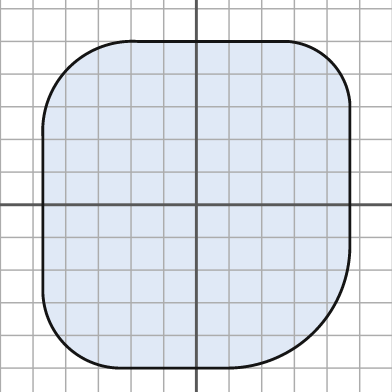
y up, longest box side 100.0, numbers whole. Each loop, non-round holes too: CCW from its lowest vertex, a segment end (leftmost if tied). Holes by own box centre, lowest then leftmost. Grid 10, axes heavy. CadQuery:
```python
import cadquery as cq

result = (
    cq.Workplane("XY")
    .moveTo(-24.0, -50.0)
    .lineTo(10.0, -50.0)
    .threePointArc((36.0, -39.0), (47.0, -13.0))
    .lineTo(47.0, 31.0)
    .threePointArc((41.0, 44.0), (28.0, 50.0))
    .lineTo(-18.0, 50.0)
    .threePointArc((-39.0, 42.0), (-47.0, 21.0))
    .lineTo(-47.0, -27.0)
    .threePointArc((-40.0, -43.0), (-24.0, -50.0))
    .close()
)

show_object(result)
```